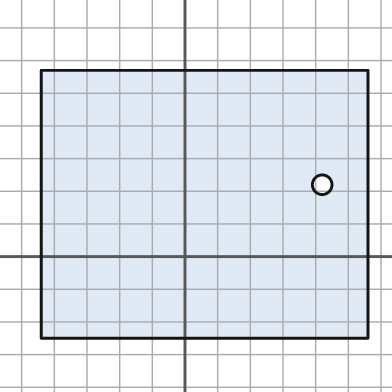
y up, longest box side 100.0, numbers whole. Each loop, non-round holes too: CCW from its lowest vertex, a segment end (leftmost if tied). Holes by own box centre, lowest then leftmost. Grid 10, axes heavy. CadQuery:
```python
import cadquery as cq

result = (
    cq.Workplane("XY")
    .moveTo(-44.0, -25.0)
    .lineTo(56.0, -25.0)
    .lineTo(56.0, 57.0)
    .lineTo(-44.0, 57.0)
    .close()
    .moveTo(42.0, 22.0)
    .circle(3.0)
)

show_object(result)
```